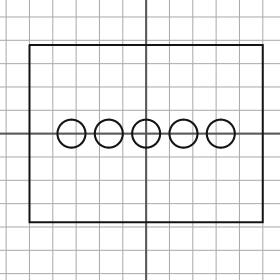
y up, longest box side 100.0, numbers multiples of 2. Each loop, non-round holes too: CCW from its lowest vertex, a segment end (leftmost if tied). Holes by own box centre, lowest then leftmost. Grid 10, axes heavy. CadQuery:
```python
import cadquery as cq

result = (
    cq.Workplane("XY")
    .moveTo(-50.0, -38.0)
    .lineTo(50.0, -38.0)
    .lineTo(50.0, 38.0)
    .lineTo(-50.0, 38.0)
    .close()
    .moveTo(-32.0, 0.0)
    .circle(6.0)
    .moveTo(-16.0, 0.0)
    .circle(6.0)
    .moveTo(0.0, 0.0)
    .circle(6.0)
    .moveTo(16.0, 0.0)
    .circle(6.0)
    .moveTo(32.0, 0.0)
    .circle(6.0)
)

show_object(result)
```